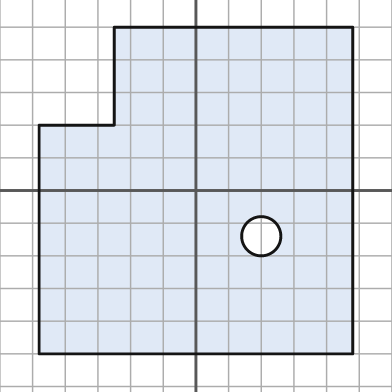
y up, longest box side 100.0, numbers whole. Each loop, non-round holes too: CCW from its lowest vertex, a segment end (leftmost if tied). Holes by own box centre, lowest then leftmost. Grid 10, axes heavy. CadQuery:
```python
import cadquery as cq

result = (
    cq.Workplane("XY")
    .moveTo(-48.0, -50.0)
    .lineTo(48.0, -50.0)
    .lineTo(48.0, 50.0)
    .lineTo(-25.0, 50.0)
    .lineTo(-25.0, 20.0)
    .lineTo(-48.0, 20.0)
    .close()
    .moveTo(20.0, -14.0)
    .circle(6.0)
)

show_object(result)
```